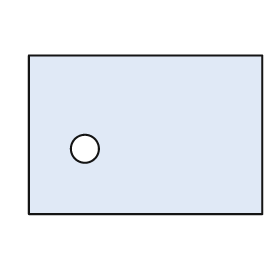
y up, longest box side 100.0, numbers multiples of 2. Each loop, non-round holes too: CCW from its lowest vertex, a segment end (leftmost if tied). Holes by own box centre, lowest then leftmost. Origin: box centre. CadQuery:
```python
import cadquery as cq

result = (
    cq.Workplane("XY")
    .moveTo(-50.0, -34.0)
    .lineTo(50.0, -34.0)
    .lineTo(50.0, 34.0)
    .lineTo(-50.0, 34.0)
    .close()
    .moveTo(-26.0, -6.0)
    .circle(6.0)
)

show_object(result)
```